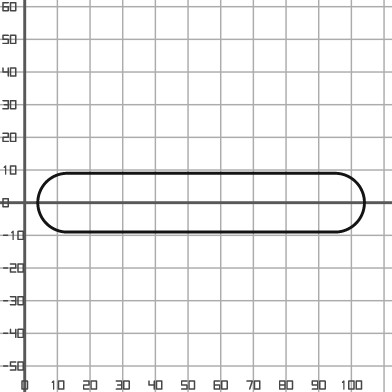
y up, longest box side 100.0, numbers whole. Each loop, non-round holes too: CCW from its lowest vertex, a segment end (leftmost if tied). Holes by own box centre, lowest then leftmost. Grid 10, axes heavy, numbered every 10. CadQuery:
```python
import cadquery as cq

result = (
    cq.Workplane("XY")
    .moveTo(13.0, -9.0)
    .lineTo(95.0, -9.0)
    .threePointArc((104.0, 0.0), (95.0, 9.0))
    .lineTo(13.0, 9.0)
    .threePointArc((4.0, 0.0), (13.0, -9.0))
    .close()
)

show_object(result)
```